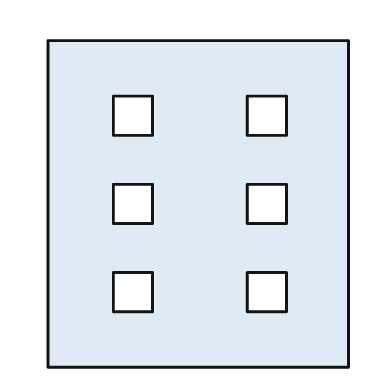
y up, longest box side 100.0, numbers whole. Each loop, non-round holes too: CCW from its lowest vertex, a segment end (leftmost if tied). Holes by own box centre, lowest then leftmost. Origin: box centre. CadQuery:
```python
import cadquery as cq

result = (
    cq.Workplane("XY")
    .moveTo(-46.0, -50.0)
    .lineTo(46.0, -50.0)
    .lineTo(46.0, 50.0)
    .lineTo(-46.0, 50.0)
    .close()
    .moveTo(-26.0, -33.0)
    .lineTo(-14.0, -33.0)
    .lineTo(-14.0, -21.0)
    .lineTo(-26.0, -21.0)
    .close()
    .moveTo(15.0, -33.0)
    .lineTo(27.0, -33.0)
    .lineTo(27.0, -21.0)
    .lineTo(15.0, -21.0)
    .close()
    .moveTo(-26.0, -6.0)
    .lineTo(-14.0, -6.0)
    .lineTo(-14.0, 6.0)
    .lineTo(-26.0, 6.0)
    .close()
    .moveTo(15.0, -6.0)
    .lineTo(27.0, -6.0)
    .lineTo(27.0, 6.0)
    .lineTo(15.0, 6.0)
    .close()
    .moveTo(-26.0, 21.0)
    .lineTo(-14.0, 21.0)
    .lineTo(-14.0, 33.0)
    .lineTo(-26.0, 33.0)
    .close()
    .moveTo(15.0, 21.0)
    .lineTo(27.0, 21.0)
    .lineTo(27.0, 33.0)
    .lineTo(15.0, 33.0)
    .close()
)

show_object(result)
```